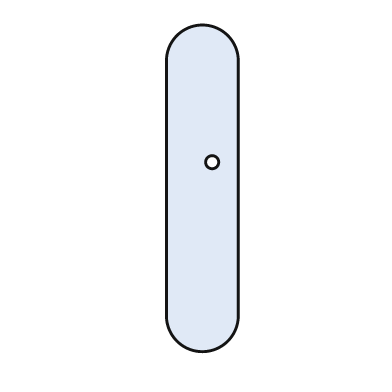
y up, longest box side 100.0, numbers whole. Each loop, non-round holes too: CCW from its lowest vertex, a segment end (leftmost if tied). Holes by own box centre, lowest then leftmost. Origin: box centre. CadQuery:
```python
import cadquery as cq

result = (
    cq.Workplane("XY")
    .moveTo(-11.0, -39.0)
    .threePointArc((0.0, -50.0), (11.0, -39.0))
    .lineTo(11.0, 39.0)
    .threePointArc((0.0, 50.0), (-11.0, 39.0))
    .close()
    .moveTo(3.0, 8.0)
    .circle(2.0)
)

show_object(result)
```